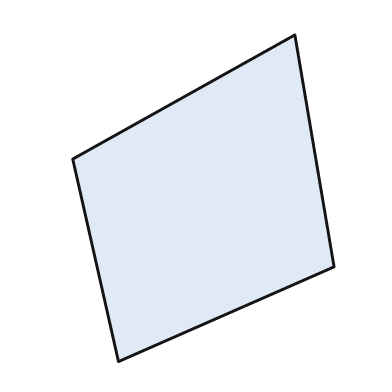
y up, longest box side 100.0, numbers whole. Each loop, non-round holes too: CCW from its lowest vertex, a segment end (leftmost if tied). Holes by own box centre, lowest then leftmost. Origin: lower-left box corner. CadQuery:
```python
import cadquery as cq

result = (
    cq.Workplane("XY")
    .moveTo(14.0, 0.0)
    .lineTo(80.0, 29.0)
    .lineTo(68.0, 100.0)
    .lineTo(0.0, 62.0)
    .close()
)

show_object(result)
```